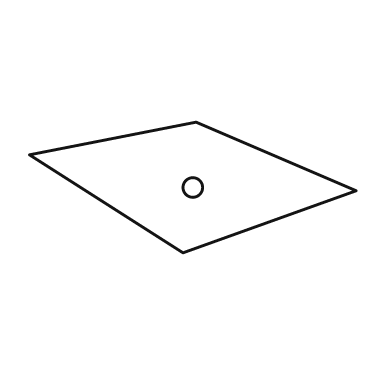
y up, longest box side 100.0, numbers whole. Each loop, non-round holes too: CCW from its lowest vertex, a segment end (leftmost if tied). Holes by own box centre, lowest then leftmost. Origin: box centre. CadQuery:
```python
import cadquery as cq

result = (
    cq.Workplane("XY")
    .moveTo(-3.0, -20.0)
    .lineTo(50.0, -1.0)
    .lineTo(1.0, 20.0)
    .lineTo(-50.0, 10.0)
    .close()
    .moveTo(0.0, 0.0)
    .circle(3.0)
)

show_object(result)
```